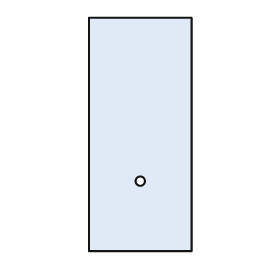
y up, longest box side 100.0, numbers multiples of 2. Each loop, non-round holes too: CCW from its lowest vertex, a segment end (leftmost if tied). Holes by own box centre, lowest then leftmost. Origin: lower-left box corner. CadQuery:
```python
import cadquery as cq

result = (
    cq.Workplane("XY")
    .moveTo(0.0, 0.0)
    .lineTo(44.0, 0.0)
    .lineTo(44.0, 100.0)
    .lineTo(0.0, 100.0)
    .close()
    .moveTo(22.0, 30.0)
    .circle(2.0)
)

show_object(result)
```